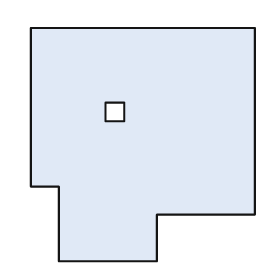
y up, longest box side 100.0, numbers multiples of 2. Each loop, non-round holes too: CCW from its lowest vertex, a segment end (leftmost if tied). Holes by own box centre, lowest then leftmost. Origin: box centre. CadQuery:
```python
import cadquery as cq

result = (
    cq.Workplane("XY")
    .moveTo(-36.0, -50.0)
    .lineTo(6.0, -50.0)
    .lineTo(6.0, -30.0)
    .lineTo(48.0, -30.0)
    .lineTo(48.0, 50.0)
    .lineTo(-48.0, 50.0)
    .lineTo(-48.0, -18.0)
    .lineTo(-36.0, -18.0)
    .close()
    .moveTo(-16.0, 10.0)
    .lineTo(-8.0, 10.0)
    .lineTo(-8.0, 18.0)
    .lineTo(-16.0, 18.0)
    .close()
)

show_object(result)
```